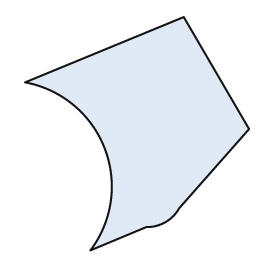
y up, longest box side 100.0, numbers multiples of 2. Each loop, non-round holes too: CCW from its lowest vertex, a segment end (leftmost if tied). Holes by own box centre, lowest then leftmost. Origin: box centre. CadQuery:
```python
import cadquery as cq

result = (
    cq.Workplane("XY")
    .moveTo(-20.0, -50.0)
    .lineTo(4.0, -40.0)
    .threePointArc((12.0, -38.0), (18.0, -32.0))
    .lineTo(48.0, 2.0)
    .lineTo(20.0, 50.0)
    .lineTo(-48.0, 22.0)
    .threePointArc((-14.0, -6.0), (-20.0, -50.0))
    .close()
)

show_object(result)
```